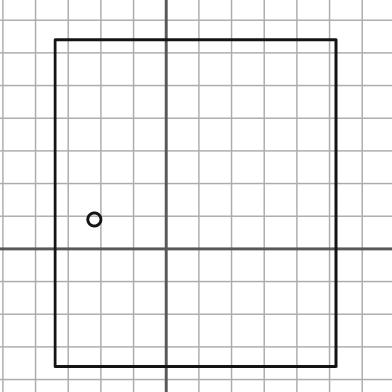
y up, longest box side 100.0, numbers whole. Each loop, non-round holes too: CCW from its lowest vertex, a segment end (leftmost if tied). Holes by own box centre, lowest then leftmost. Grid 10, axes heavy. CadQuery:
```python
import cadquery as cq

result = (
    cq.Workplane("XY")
    .moveTo(-34.0, -36.0)
    .lineTo(52.0, -36.0)
    .lineTo(52.0, 64.0)
    .lineTo(-34.0, 64.0)
    .close()
    .moveTo(-22.0, 9.0)
    .circle(2.0)
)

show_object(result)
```